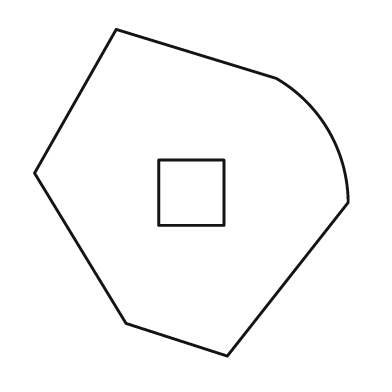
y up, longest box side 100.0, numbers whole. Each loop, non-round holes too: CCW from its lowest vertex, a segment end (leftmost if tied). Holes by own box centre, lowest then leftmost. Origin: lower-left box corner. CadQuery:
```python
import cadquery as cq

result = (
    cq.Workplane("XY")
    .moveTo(59.0, 0.0)
    .lineTo(96.0, 47.0)
    .threePointArc((90.0, 69.0), (74.0, 85.0))
    .lineTo(25.0, 100.0)
    .lineTo(0.0, 56.0)
    .lineTo(28.0, 10.0)
    .close()
    .moveTo(38.0, 40.0)
    .lineTo(58.0, 40.0)
    .lineTo(58.0, 60.0)
    .lineTo(38.0, 60.0)
    .close()
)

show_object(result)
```